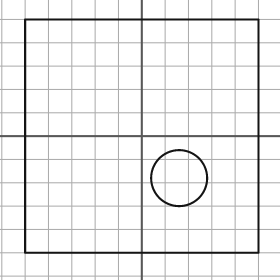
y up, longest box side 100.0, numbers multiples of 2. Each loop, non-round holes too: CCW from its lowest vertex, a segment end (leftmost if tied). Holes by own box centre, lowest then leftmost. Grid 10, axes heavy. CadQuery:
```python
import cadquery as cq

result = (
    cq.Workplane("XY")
    .moveTo(-50.0, -50.0)
    .lineTo(50.0, -50.0)
    .lineTo(50.0, 50.0)
    .lineTo(-50.0, 50.0)
    .close()
    .moveTo(16.0, -18.0)
    .circle(12.0)
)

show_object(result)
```